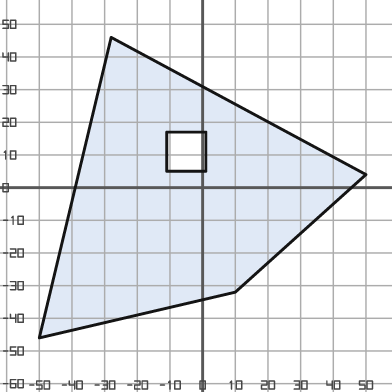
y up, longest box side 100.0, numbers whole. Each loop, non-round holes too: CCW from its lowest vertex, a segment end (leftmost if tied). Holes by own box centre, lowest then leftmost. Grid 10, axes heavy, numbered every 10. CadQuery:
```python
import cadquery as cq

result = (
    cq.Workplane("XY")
    .moveTo(-50.0, -46.0)
    .lineTo(10.0, -32.0)
    .lineTo(50.0, 4.0)
    .lineTo(-28.0, 46.0)
    .close()
    .moveTo(-11.0, 5.0)
    .lineTo(1.0, 5.0)
    .lineTo(1.0, 17.0)
    .lineTo(-11.0, 17.0)
    .close()
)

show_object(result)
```